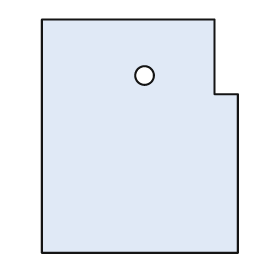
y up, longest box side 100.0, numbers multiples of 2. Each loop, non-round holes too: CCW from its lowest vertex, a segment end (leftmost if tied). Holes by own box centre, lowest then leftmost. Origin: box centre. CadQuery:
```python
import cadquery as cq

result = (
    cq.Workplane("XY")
    .moveTo(-42.0, -50.0)
    .lineTo(42.0, -50.0)
    .lineTo(42.0, 18.0)
    .lineTo(32.0, 18.0)
    .lineTo(32.0, 50.0)
    .lineTo(-42.0, 50.0)
    .close()
    .moveTo(2.0, 26.0)
    .circle(4.0)
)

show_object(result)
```